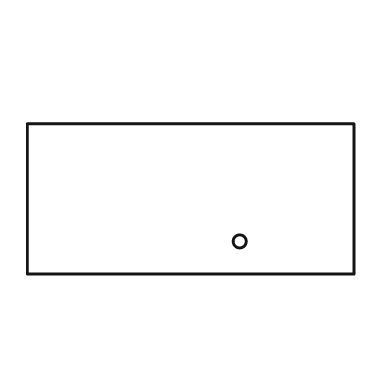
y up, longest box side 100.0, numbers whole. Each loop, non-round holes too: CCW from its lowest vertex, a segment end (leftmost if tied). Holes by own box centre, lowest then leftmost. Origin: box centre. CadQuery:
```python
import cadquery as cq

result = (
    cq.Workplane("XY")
    .moveTo(-50.0, -23.0)
    .lineTo(50.0, -23.0)
    .lineTo(50.0, 23.0)
    .lineTo(-50.0, 23.0)
    .close()
    .moveTo(15.0, -13.0)
    .circle(2.0)
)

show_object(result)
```